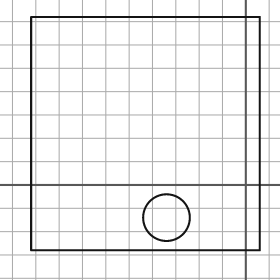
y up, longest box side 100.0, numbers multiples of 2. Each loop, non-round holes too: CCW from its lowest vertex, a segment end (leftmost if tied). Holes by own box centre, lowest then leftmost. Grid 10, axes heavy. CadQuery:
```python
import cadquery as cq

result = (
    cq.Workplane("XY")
    .moveTo(-92.0, -28.0)
    .lineTo(6.0, -28.0)
    .lineTo(6.0, 72.0)
    .lineTo(-92.0, 72.0)
    .close()
    .moveTo(-34.0, -14.0)
    .circle(10.0)
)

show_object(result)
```